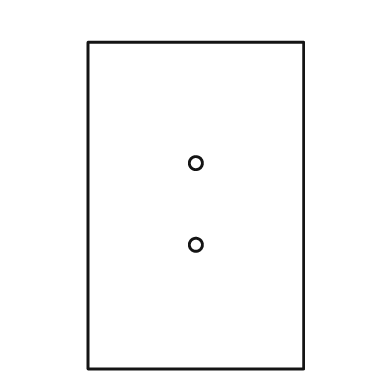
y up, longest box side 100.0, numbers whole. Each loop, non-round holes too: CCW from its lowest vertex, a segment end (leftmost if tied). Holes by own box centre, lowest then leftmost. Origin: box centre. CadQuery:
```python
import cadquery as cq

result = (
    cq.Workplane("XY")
    .moveTo(-33.0, -50.0)
    .lineTo(33.0, -50.0)
    .lineTo(33.0, 50.0)
    .lineTo(-33.0, 50.0)
    .close()
    .moveTo(0.0, -12.0)
    .circle(2.0)
    .moveTo(0.0, 13.0)
    .circle(2.0)
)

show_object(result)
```